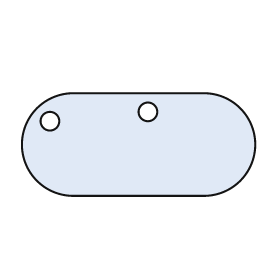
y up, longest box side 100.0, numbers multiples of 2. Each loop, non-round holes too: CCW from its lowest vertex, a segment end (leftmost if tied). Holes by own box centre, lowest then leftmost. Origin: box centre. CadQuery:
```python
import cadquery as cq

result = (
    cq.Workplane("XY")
    .moveTo(-28.0, -22.0)
    .lineTo(28.0, -22.0)
    .threePointArc((50.0, 0.0), (28.0, 22.0))
    .lineTo(-28.0, 22.0)
    .threePointArc((-50.0, 0.0), (-28.0, -22.0))
    .close()
    .moveTo(-38.0, 10.0)
    .circle(4.0)
    .moveTo(4.0, 14.0)
    .circle(4.0)
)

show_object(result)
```